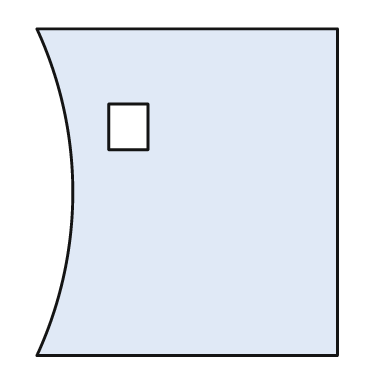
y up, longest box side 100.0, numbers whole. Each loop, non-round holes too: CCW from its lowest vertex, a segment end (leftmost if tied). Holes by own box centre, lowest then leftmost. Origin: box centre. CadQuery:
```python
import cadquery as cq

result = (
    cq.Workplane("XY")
    .moveTo(-46.0, -50.0)
    .lineTo(46.0, -50.0)
    .lineTo(46.0, 50.0)
    .lineTo(-46.0, 50.0)
    .threePointArc((-35.0, 0.0), (-46.0, -50.0))
    .close()
    .moveTo(-24.0, 13.0)
    .lineTo(-12.0, 13.0)
    .lineTo(-12.0, 27.0)
    .lineTo(-24.0, 27.0)
    .close()
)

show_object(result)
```